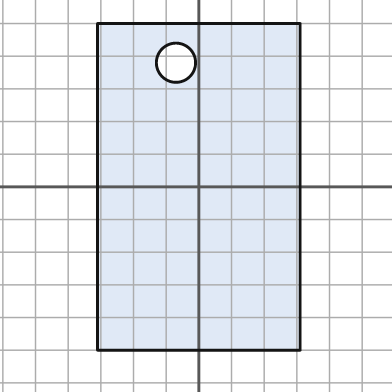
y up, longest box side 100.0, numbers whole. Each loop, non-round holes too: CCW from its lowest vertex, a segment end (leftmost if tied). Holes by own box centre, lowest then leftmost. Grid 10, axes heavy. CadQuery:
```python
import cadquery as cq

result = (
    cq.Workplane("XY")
    .moveTo(-31.0, -50.0)
    .lineTo(31.0, -50.0)
    .lineTo(31.0, 50.0)
    .lineTo(-31.0, 50.0)
    .close()
    .moveTo(-7.0, 38.0)
    .circle(6.0)
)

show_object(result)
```